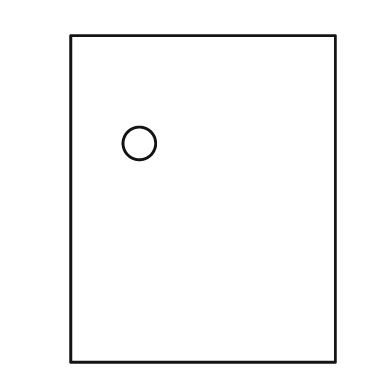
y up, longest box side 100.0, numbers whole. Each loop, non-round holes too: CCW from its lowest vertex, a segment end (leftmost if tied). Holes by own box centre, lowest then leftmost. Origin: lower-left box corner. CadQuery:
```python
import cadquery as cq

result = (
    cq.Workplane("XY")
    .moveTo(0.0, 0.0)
    .lineTo(81.0, 0.0)
    .lineTo(81.0, 100.0)
    .lineTo(0.0, 100.0)
    .close()
    .moveTo(21.0, 67.0)
    .circle(5.0)
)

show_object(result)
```